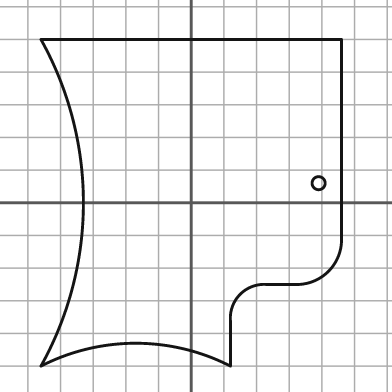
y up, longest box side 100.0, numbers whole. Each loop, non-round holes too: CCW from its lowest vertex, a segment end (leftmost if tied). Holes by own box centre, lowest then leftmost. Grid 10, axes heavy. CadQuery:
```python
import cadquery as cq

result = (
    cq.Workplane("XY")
    .moveTo(-46.0, -50.0)
    .threePointArc((-17.0, -43.0), (12.0, -50.0))
    .lineTo(12.0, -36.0)
    .threePointArc((15.0, -28.0), (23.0, -25.0))
    .lineTo(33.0, -25.0)
    .threePointArc((42.0, -21.0), (46.0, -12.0))
    .lineTo(46.0, 50.0)
    .lineTo(-46.0, 50.0)
    .threePointArc((-33.0, 0.0), (-46.0, -50.0))
    .close()
    .moveTo(39.0, 6.0)
    .circle(2.0)
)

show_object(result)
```